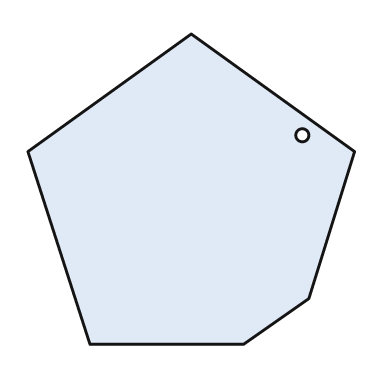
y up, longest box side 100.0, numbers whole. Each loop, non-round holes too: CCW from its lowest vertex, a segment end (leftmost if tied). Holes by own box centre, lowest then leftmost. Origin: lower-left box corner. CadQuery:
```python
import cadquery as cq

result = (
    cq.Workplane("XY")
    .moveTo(19.0, 0.0)
    .lineTo(66.0, 0.0)
    .lineTo(86.0, 14.0)
    .lineTo(100.0, 59.0)
    .lineTo(50.0, 95.0)
    .lineTo(0.0, 59.0)
    .close()
    .moveTo(84.0, 64.0)
    .circle(2.0)
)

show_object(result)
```